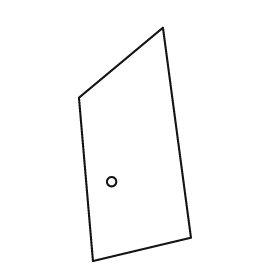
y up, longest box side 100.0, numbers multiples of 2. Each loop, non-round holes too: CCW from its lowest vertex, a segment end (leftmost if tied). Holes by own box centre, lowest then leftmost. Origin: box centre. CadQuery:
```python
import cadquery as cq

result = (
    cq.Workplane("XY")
    .moveTo(-18.0, -50.0)
    .lineTo(24.0, -40.0)
    .lineTo(12.0, 50.0)
    .lineTo(-24.0, 20.0)
    .close()
    .moveTo(-10.0, -16.0)
    .circle(2.0)
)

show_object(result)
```